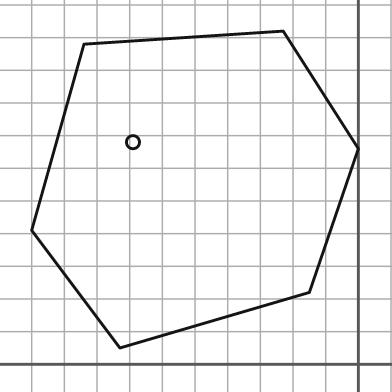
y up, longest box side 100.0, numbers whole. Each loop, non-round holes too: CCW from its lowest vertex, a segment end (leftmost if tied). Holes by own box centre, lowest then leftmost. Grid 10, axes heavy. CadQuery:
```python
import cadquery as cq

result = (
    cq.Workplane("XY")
    .moveTo(-73.0, 5.0)
    .lineTo(-15.0, 22.0)
    .lineTo(0.0, 66.0)
    .lineTo(-23.0, 102.0)
    .lineTo(-84.0, 98.0)
    .lineTo(-100.0, 41.0)
    .close()
    .moveTo(-69.0, 68.0)
    .circle(2.0)
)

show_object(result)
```